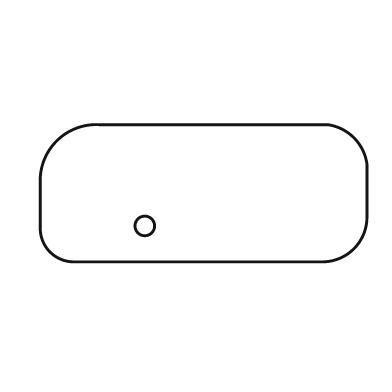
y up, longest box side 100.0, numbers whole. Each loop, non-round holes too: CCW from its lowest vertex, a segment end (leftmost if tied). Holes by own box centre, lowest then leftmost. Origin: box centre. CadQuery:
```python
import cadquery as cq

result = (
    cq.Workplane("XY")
    .moveTo(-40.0, -21.0)
    .lineTo(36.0, -21.0)
    .threePointArc((46.0, -17.0), (50.0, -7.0))
    .lineTo(50.0, 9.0)
    .threePointArc((46.0, 17.0), (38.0, 21.0))
    .lineTo(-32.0, 21.0)
    .threePointArc((-45.0, 16.0), (-50.0, 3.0))
    .lineTo(-50.0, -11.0)
    .threePointArc((-47.0, -18.0), (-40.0, -21.0))
    .close()
    .moveTo(-18.0, -10.0)
    .circle(3.0)
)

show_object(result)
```